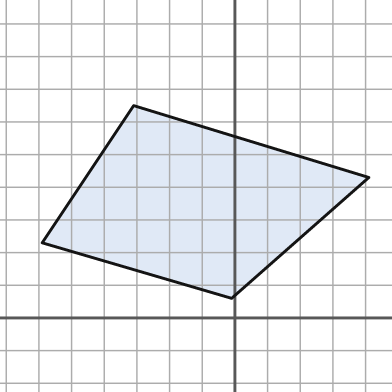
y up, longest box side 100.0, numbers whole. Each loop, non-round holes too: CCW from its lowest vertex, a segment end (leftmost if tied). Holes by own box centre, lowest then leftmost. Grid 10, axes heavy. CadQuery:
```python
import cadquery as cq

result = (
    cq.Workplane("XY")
    .moveTo(-1.0, 6.0)
    .lineTo(41.0, 43.0)
    .lineTo(-31.0, 65.0)
    .lineTo(-59.0, 23.0)
    .close()
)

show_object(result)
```